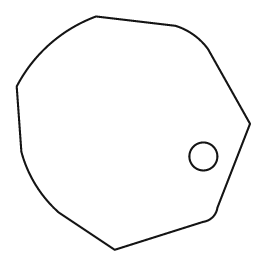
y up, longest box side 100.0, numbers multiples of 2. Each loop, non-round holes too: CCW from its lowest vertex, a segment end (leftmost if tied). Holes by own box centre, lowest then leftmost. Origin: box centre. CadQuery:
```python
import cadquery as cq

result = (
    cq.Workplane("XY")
    .moveTo(-8.0, -50.0)
    .lineTo(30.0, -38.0)
    .threePointArc((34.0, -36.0), (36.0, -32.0))
    .lineTo(50.0, 4.0)
    .lineTo(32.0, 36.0)
    .threePointArc((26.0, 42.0), (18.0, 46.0))
    .lineTo(-16.0, 50.0)
    .threePointArc((-36.0, 38.0), (-50.0, 20.0))
    .lineTo(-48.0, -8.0)
    .threePointArc((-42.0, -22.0), (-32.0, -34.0))
    .close()
    .moveTo(30.0, -10.0)
    .circle(6.0)
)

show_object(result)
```